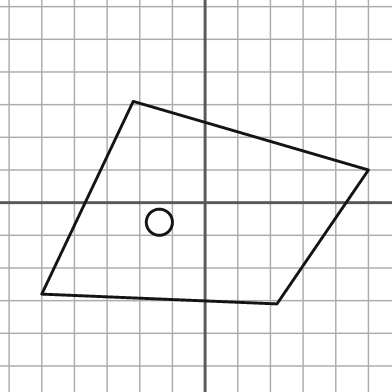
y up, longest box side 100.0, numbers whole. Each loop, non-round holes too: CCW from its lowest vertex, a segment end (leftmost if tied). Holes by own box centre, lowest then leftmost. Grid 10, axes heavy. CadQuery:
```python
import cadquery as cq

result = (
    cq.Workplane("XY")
    .moveTo(22.0, -31.0)
    .lineTo(50.0, 10.0)
    .lineTo(-22.0, 31.0)
    .lineTo(-50.0, -28.0)
    .close()
    .moveTo(-14.0, -6.0)
    .circle(4.0)
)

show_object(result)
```